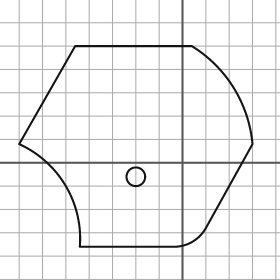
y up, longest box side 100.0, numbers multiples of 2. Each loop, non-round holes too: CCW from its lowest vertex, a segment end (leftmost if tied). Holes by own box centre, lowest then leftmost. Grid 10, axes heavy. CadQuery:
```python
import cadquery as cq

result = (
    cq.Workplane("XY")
    .moveTo(-44.0, -36.0)
    .lineTo(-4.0, -36.0)
    .threePointArc((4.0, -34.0), (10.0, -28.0))
    .lineTo(30.0, 8.0)
    .threePointArc((22.0, 32.0), (4.0, 50.0))
    .lineTo(-46.0, 50.0)
    .lineTo(-70.0, 8.0)
    .threePointArc((-50.0, -10.0), (-44.0, -36.0))
    .close()
    .moveTo(-20.0, -6.0)
    .circle(4.0)
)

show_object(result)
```